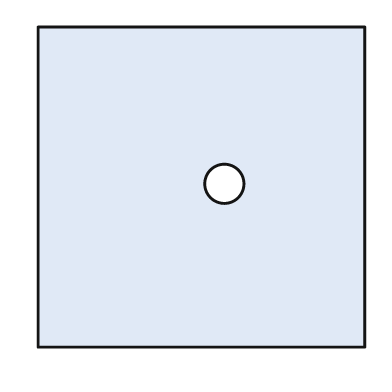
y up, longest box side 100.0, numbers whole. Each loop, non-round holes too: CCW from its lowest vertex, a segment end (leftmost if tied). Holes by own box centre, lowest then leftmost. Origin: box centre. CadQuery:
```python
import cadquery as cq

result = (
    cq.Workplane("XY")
    .moveTo(-50.0, -49.0)
    .lineTo(50.0, -49.0)
    .lineTo(50.0, 49.0)
    .lineTo(-50.0, 49.0)
    .close()
    .moveTo(7.0, 1.0)
    .circle(6.0)
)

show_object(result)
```